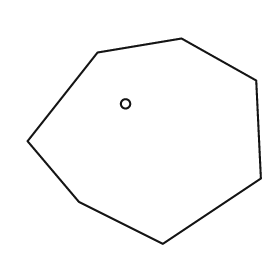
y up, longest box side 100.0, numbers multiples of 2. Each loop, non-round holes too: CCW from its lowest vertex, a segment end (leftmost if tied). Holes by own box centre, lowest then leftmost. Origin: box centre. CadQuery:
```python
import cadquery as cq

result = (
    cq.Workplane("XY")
    .moveTo(8.0, -44.0)
    .lineTo(50.0, -16.0)
    .lineTo(48.0, 26.0)
    .lineTo(16.0, 44.0)
    .lineTo(-20.0, 38.0)
    .lineTo(-50.0, 0.0)
    .lineTo(-28.0, -26.0)
    .close()
    .moveTo(-8.0, 16.0)
    .circle(2.0)
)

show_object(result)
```